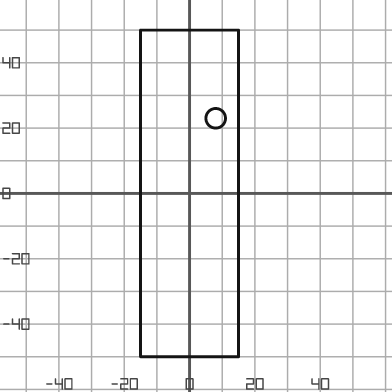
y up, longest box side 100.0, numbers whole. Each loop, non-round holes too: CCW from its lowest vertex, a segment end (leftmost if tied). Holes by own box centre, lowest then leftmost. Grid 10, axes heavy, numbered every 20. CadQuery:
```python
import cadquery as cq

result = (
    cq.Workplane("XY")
    .moveTo(-15.0, -50.0)
    .lineTo(15.0, -50.0)
    .lineTo(15.0, 50.0)
    .lineTo(-15.0, 50.0)
    .close()
    .moveTo(8.0, 23.0)
    .circle(3.0)
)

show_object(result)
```